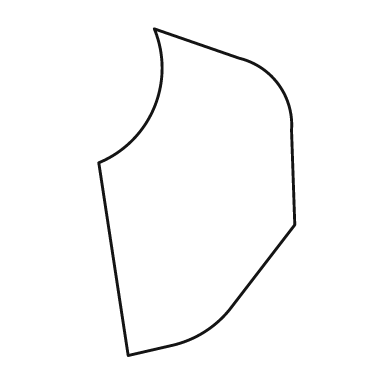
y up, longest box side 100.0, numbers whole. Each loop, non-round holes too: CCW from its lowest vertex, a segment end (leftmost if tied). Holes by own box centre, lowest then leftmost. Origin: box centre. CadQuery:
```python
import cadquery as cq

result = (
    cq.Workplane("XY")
    .moveTo(-21.0, -50.0)
    .lineTo(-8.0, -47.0)
    .threePointArc((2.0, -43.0), (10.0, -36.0))
    .lineTo(30.0, -10.0)
    .lineTo(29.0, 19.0)
    .threePointArc((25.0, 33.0), (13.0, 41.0))
    .lineTo(-13.0, 50.0)
    .threePointArc((-13.0, 26.0), (-30.0, 9.0))
    .close()
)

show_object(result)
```